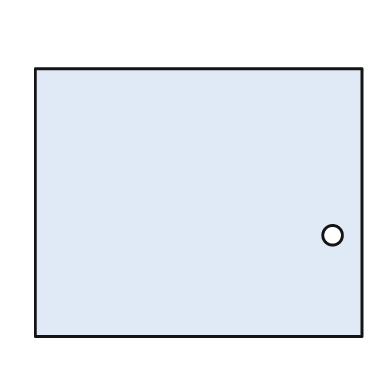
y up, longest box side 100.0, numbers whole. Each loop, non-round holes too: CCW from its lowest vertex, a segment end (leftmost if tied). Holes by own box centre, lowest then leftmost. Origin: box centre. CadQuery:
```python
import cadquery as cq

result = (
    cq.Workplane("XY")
    .moveTo(-50.0, -41.0)
    .lineTo(50.0, -41.0)
    .lineTo(50.0, 41.0)
    .lineTo(-50.0, 41.0)
    .close()
    .moveTo(41.0, -10.0)
    .circle(3.0)
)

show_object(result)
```